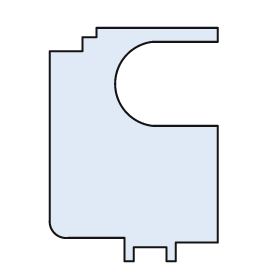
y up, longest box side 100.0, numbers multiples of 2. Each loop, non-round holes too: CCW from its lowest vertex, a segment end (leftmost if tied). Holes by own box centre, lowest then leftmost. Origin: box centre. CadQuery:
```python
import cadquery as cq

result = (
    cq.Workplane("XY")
    .moveTo(-4.0, -50.0)
    .lineTo(0.0, -50.0)
    .lineTo(0.0, -44.0)
    .lineTo(14.0, -44.0)
    .lineTo(14.0, -50.0)
    .lineTo(18.0, -50.0)
    .lineTo(18.0, -42.0)
    .lineTo(36.0, -42.0)
    .lineTo(36.0, 8.0)
    .lineTo(8.0, 8.0)
    .threePointArc((-8.0, 26.0), (8.0, 44.0))
    .lineTo(36.0, 44.0)
    .lineTo(36.0, 50.0)
    .lineTo(-16.0, 50.0)
    .lineTo(-16.0, 46.0)
    .lineTo(-22.0, 46.0)
    .lineTo(-22.0, 40.0)
    .lineTo(-36.0, 40.0)
    .lineTo(-36.0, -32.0)
    .threePointArc((-34.0, -38.0), (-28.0, -40.0))
    .lineTo(-4.0, -40.0)
    .close()
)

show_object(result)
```